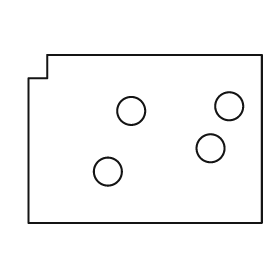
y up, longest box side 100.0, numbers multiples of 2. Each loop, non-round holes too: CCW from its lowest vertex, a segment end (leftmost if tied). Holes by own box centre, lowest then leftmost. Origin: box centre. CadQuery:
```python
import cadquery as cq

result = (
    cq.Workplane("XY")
    .moveTo(-50.0, -36.0)
    .lineTo(50.0, -36.0)
    .lineTo(50.0, 36.0)
    .lineTo(-42.0, 36.0)
    .lineTo(-42.0, 26.0)
    .lineTo(-50.0, 26.0)
    .close()
    .moveTo(-16.0, -14.0)
    .circle(6.0)
    .moveTo(28.0, -4.0)
    .circle(6.0)
    .moveTo(-6.0, 12.0)
    .circle(6.0)
    .moveTo(36.0, 14.0)
    .circle(6.0)
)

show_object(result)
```